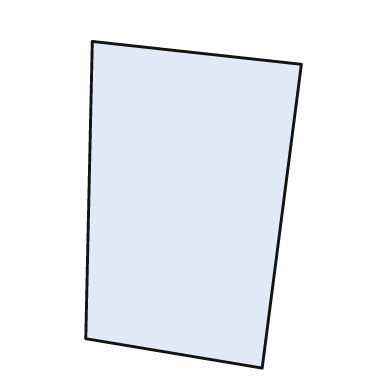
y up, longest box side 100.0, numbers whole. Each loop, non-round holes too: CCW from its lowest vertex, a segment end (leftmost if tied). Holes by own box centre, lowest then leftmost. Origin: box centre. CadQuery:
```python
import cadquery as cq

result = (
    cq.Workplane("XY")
    .moveTo(21.0, -50.0)
    .lineTo(33.0, 43.0)
    .lineTo(-31.0, 50.0)
    .lineTo(-33.0, -41.0)
    .close()
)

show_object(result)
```